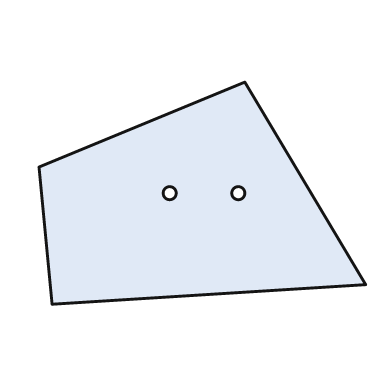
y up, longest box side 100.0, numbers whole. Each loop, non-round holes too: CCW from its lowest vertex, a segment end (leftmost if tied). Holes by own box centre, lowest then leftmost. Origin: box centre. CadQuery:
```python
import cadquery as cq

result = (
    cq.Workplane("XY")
    .moveTo(-46.0, -34.0)
    .lineTo(50.0, -28.0)
    .lineTo(13.0, 34.0)
    .lineTo(-50.0, 8.0)
    .close()
    .moveTo(-10.0, 0.0)
    .circle(2.0)
    .moveTo(11.0, 0.0)
    .circle(2.0)
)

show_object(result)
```